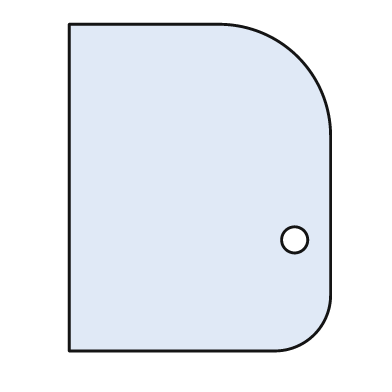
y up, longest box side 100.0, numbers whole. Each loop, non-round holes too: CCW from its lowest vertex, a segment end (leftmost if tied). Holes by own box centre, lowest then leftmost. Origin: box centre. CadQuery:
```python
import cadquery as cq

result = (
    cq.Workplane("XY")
    .moveTo(-40.0, -50.0)
    .lineTo(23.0, -50.0)
    .threePointArc((35.0, -45.0), (40.0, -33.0))
    .lineTo(40.0, 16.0)
    .threePointArc((30.0, 40.0), (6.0, 50.0))
    .lineTo(-40.0, 50.0)
    .close()
    .moveTo(29.0, -16.0)
    .circle(4.0)
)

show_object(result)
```